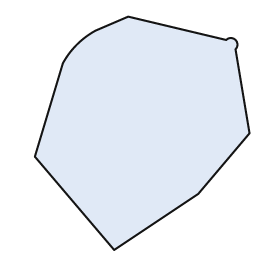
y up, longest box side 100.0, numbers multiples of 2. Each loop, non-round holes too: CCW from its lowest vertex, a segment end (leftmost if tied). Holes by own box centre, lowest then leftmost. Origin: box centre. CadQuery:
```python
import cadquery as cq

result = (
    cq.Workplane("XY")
    .moveTo(-12.0, -50.0)
    .lineTo(24.0, -26.0)
    .lineTo(46.0, 0.0)
    .lineTo(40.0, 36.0)
    .threePointArc((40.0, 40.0), (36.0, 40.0))
    .lineTo(-6.0, 50.0)
    .lineTo(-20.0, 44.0)
    .threePointArc((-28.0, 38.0), (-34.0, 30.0))
    .lineTo(-46.0, -10.0)
    .close()
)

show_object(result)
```